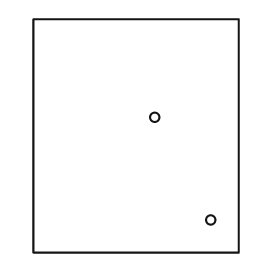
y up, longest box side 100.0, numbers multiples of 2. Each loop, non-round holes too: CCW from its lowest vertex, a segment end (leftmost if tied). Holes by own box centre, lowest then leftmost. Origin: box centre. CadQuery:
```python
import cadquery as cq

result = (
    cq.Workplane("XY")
    .moveTo(-44.0, -50.0)
    .lineTo(44.0, -50.0)
    .lineTo(44.0, 50.0)
    .lineTo(-44.0, 50.0)
    .close()
    .moveTo(32.0, -36.0)
    .circle(2.0)
    .moveTo(8.0, 8.0)
    .circle(2.0)
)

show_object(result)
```